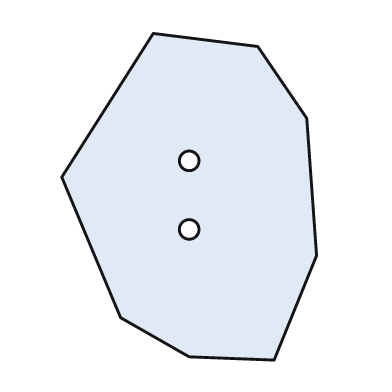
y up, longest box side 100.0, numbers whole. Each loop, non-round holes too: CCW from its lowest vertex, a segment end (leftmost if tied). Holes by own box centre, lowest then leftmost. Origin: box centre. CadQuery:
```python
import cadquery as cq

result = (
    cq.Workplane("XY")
    .moveTo(26.0, -50.0)
    .lineTo(39.0, -18.0)
    .lineTo(36.0, 24.0)
    .lineTo(21.0, 46.0)
    .lineTo(-11.0, 50.0)
    .lineTo(-39.0, 6.0)
    .lineTo(-21.0, -37.0)
    .lineTo(0.0, -49.0)
    .close()
    .moveTo(0.0, -10.0)
    .circle(3.0)
    .moveTo(0.0, 11.0)
    .circle(3.0)
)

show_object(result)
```